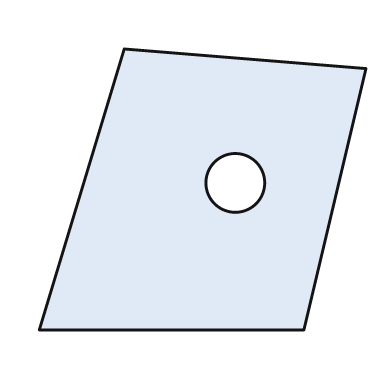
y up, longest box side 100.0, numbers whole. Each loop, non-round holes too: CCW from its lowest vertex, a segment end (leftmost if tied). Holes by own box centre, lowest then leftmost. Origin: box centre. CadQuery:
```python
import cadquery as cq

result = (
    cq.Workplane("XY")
    .moveTo(-50.0, -43.0)
    .lineTo(31.0, -43.0)
    .lineTo(50.0, 37.0)
    .lineTo(-24.0, 43.0)
    .close()
    .moveTo(10.0, 2.0)
    .circle(9.0)
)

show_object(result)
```